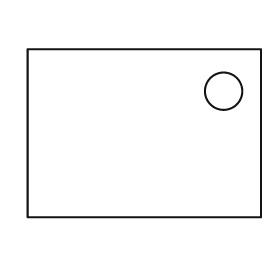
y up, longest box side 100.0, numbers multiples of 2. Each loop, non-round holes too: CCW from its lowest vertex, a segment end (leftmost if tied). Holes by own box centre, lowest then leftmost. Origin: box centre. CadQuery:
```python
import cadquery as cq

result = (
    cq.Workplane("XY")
    .moveTo(-50.0, -36.0)
    .lineTo(50.0, -36.0)
    .lineTo(50.0, 36.0)
    .lineTo(-50.0, 36.0)
    .close()
    .moveTo(34.0, 18.0)
    .circle(8.0)
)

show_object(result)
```